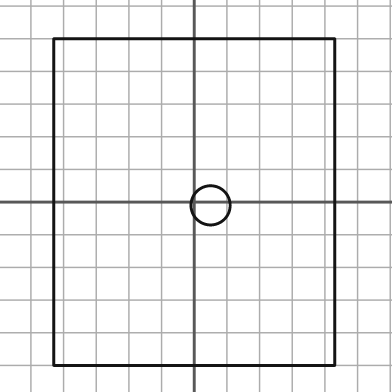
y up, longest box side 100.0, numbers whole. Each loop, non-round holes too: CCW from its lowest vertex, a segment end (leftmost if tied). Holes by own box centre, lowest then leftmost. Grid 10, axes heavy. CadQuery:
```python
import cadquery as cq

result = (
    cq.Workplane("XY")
    .moveTo(-43.0, -50.0)
    .lineTo(43.0, -50.0)
    .lineTo(43.0, 50.0)
    .lineTo(-43.0, 50.0)
    .close()
    .moveTo(5.0, -1.0)
    .circle(6.0)
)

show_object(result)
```